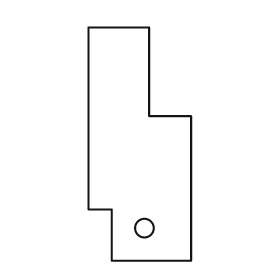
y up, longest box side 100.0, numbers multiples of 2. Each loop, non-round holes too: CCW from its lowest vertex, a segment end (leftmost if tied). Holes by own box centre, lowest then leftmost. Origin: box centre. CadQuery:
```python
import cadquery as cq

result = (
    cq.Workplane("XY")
    .moveTo(-12.0, -50.0)
    .lineTo(22.0, -50.0)
    .lineTo(22.0, 12.0)
    .lineTo(4.0, 12.0)
    .lineTo(4.0, 50.0)
    .lineTo(-22.0, 50.0)
    .lineTo(-22.0, -28.0)
    .lineTo(-12.0, -28.0)
    .close()
    .moveTo(2.0, -36.0)
    .circle(4.0)
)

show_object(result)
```